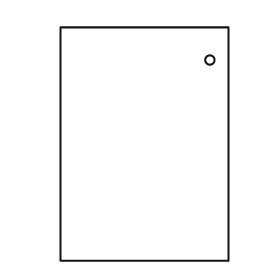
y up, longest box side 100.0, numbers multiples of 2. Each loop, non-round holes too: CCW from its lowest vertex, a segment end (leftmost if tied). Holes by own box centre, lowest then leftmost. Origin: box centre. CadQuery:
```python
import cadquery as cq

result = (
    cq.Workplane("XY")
    .moveTo(-36.0, -50.0)
    .lineTo(36.0, -50.0)
    .lineTo(36.0, 50.0)
    .lineTo(-36.0, 50.0)
    .close()
    .moveTo(28.0, 36.0)
    .circle(2.0)
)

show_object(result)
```